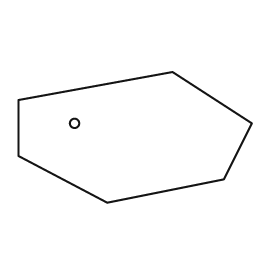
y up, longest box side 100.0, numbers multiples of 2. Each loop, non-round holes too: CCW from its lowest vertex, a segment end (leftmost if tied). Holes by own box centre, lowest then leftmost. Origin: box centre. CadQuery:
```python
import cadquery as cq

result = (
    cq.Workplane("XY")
    .moveTo(-12.0, -28.0)
    .lineTo(38.0, -18.0)
    .lineTo(50.0, 6.0)
    .lineTo(16.0, 28.0)
    .lineTo(-50.0, 16.0)
    .lineTo(-50.0, -8.0)
    .close()
    .moveTo(-26.0, 6.0)
    .circle(2.0)
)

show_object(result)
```